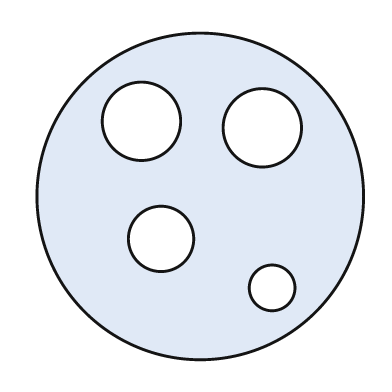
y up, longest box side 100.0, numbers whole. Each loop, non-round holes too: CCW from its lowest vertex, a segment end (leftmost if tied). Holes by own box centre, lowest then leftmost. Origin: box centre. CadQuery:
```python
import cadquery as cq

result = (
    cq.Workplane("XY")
    .moveTo(0.0, 0.0)
    .circle(50.0)
    .moveTo(22.0, -28.0)
    .circle(7.0)
    .moveTo(-12.0, -13.0)
    .circle(10.0)
    .moveTo(19.0, 21.0)
    .circle(12.0)
    .moveTo(-18.0, 23.0)
    .circle(12.0)
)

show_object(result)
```